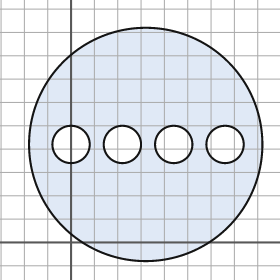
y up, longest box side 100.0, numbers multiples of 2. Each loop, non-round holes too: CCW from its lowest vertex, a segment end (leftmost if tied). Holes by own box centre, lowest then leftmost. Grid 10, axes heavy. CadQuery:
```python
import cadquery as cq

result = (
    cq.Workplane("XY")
    .moveTo(32.0, 42.0)
    .circle(50.0)
    .moveTo(0.0, 42.0)
    .circle(8.0)
    .moveTo(22.0, 42.0)
    .circle(8.0)
    .moveTo(44.0, 42.0)
    .circle(8.0)
    .moveTo(66.0, 42.0)
    .circle(8.0)
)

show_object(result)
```